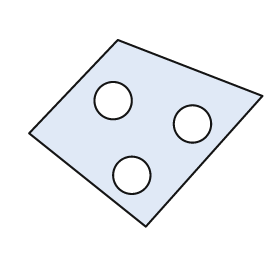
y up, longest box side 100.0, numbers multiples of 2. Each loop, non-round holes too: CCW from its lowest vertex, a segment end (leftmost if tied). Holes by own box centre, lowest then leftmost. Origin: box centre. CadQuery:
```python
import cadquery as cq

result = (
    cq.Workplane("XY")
    .moveTo(0.0, -40.0)
    .lineTo(50.0, 16.0)
    .lineTo(-12.0, 40.0)
    .lineTo(-50.0, 0.0)
    .close()
    .moveTo(-6.0, -18.0)
    .circle(8.0)
    .moveTo(20.0, 4.0)
    .circle(8.0)
    .moveTo(-14.0, 14.0)
    .circle(8.0)
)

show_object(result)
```